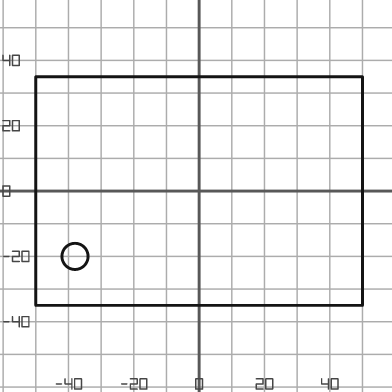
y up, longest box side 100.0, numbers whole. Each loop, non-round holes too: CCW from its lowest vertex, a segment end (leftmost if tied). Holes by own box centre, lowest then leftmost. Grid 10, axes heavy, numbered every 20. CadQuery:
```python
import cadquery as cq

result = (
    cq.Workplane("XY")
    .moveTo(-50.0, -35.0)
    .lineTo(50.0, -35.0)
    .lineTo(50.0, 35.0)
    .lineTo(-50.0, 35.0)
    .close()
    .moveTo(-38.0, -20.0)
    .circle(4.0)
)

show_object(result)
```